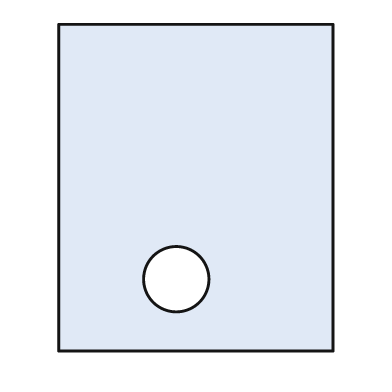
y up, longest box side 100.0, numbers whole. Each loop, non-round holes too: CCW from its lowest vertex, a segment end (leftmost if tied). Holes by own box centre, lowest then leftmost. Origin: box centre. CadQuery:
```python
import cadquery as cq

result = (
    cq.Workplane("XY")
    .moveTo(-42.0, -50.0)
    .lineTo(42.0, -50.0)
    .lineTo(42.0, 50.0)
    .lineTo(-42.0, 50.0)
    .close()
    .moveTo(-6.0, -28.0)
    .circle(10.0)
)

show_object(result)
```